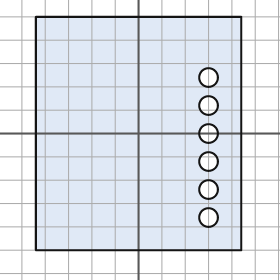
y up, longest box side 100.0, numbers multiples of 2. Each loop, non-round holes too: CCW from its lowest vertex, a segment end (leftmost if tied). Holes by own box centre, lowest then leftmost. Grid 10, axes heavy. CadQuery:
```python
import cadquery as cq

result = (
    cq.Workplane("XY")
    .moveTo(-44.0, -50.0)
    .lineTo(44.0, -50.0)
    .lineTo(44.0, 50.0)
    .lineTo(-44.0, 50.0)
    .close()
    .moveTo(30.0, -36.0)
    .circle(4.0)
    .moveTo(30.0, -24.0)
    .circle(4.0)
    .moveTo(30.0, -12.0)
    .circle(4.0)
    .moveTo(30.0, 0.0)
    .circle(4.0)
    .moveTo(30.0, 12.0)
    .circle(4.0)
    .moveTo(30.0, 24.0)
    .circle(4.0)
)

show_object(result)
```